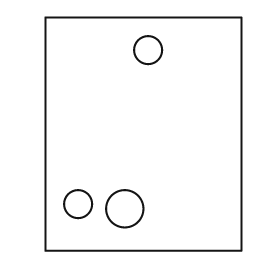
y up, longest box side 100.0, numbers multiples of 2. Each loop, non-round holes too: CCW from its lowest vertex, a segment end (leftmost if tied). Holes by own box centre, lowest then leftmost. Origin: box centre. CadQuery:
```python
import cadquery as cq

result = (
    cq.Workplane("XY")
    .moveTo(-42.0, -50.0)
    .lineTo(42.0, -50.0)
    .lineTo(42.0, 50.0)
    .lineTo(-42.0, 50.0)
    .close()
    .moveTo(-8.0, -32.0)
    .circle(8.0)
    .moveTo(-28.0, -30.0)
    .circle(6.0)
    .moveTo(2.0, 36.0)
    .circle(6.0)
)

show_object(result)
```